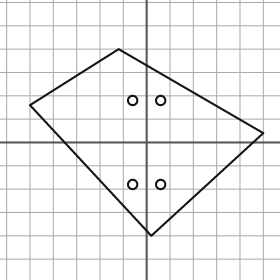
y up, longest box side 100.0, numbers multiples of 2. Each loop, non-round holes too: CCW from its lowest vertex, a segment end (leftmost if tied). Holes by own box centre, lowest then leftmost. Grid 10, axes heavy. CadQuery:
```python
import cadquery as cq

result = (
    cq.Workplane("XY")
    .moveTo(2.0, -40.0)
    .lineTo(50.0, 4.0)
    .lineTo(-12.0, 40.0)
    .lineTo(-50.0, 16.0)
    .close()
    .moveTo(-6.0, -18.0)
    .circle(2.0)
    .moveTo(6.0, -18.0)
    .circle(2.0)
    .moveTo(-6.0, 18.0)
    .circle(2.0)
    .moveTo(6.0, 18.0)
    .circle(2.0)
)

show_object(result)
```